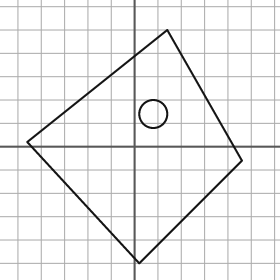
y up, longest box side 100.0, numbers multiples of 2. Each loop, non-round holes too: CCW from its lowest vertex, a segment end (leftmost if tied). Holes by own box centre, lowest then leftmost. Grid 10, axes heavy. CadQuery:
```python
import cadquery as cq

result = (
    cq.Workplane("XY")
    .moveTo(2.0, -50.0)
    .lineTo(46.0, -6.0)
    .lineTo(14.0, 50.0)
    .lineTo(-46.0, 2.0)
    .close()
    .moveTo(8.0, 14.0)
    .circle(6.0)
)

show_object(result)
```